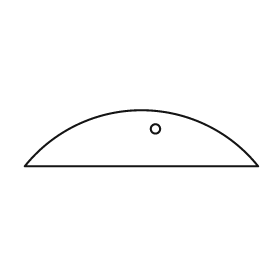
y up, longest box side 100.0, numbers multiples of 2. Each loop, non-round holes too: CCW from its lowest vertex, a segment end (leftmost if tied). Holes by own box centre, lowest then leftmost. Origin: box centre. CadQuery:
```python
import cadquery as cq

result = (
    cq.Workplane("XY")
    .moveTo(-50.0, -12.0)
    .lineTo(50.0, -12.0)
    .threePointArc((0.0, 12.0), (-50.0, -12.0))
    .close()
    .moveTo(6.0, 4.0)
    .circle(2.0)
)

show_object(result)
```